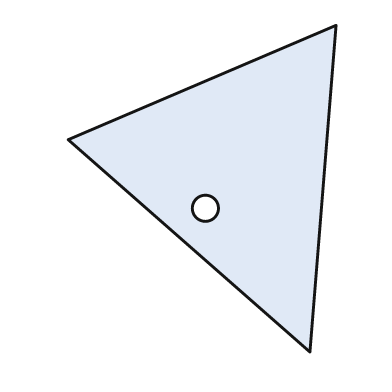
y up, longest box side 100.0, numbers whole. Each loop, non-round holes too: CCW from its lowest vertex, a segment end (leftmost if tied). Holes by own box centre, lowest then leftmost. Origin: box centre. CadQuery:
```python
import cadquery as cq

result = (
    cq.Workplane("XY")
    .moveTo(33.0, -50.0)
    .lineTo(41.0, 50.0)
    .lineTo(-41.0, 15.0)
    .close()
    .moveTo(1.0, -6.0)
    .circle(4.0)
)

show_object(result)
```